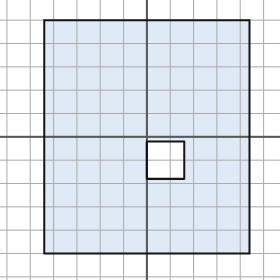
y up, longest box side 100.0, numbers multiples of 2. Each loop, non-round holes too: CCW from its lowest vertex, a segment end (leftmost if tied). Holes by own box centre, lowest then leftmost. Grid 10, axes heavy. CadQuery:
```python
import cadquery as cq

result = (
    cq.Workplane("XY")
    .moveTo(-44.0, -50.0)
    .lineTo(44.0, -50.0)
    .lineTo(44.0, 50.0)
    .lineTo(-44.0, 50.0)
    .close()
    .moveTo(0.0, -18.0)
    .lineTo(16.0, -18.0)
    .lineTo(16.0, -2.0)
    .lineTo(0.0, -2.0)
    .close()
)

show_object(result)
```